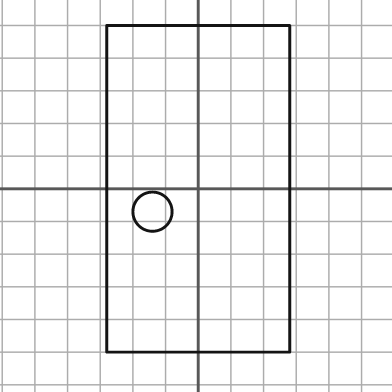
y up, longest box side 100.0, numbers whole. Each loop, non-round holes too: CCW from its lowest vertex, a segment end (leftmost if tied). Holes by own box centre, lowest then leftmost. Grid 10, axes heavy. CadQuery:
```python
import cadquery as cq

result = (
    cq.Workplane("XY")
    .moveTo(-28.0, -50.0)
    .lineTo(28.0, -50.0)
    .lineTo(28.0, 50.0)
    .lineTo(-28.0, 50.0)
    .close()
    .moveTo(-14.0, -7.0)
    .circle(6.0)
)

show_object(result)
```